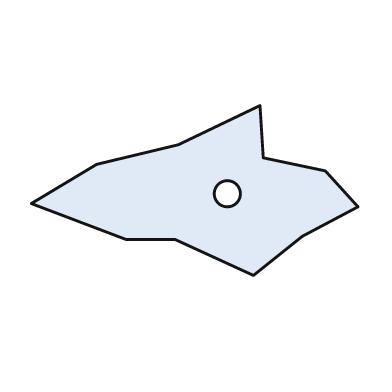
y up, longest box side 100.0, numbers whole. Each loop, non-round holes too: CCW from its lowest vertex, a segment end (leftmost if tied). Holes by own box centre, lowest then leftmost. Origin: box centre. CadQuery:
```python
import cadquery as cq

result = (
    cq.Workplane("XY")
    .moveTo(18.0, -26.0)
    .lineTo(33.0, -14.0)
    .lineTo(50.0, -5.0)
    .lineTo(40.0, 6.0)
    .lineTo(21.0, 10.0)
    .lineTo(20.0, 26.0)
    .lineTo(-5.0, 14.0)
    .lineTo(-30.0, 8.0)
    .lineTo(-50.0, -4.0)
    .lineTo(-21.0, -15.0)
    .lineTo(-6.0, -15.0)
    .close()
    .moveTo(10.0, -1.0)
    .circle(4.0)
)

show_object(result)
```